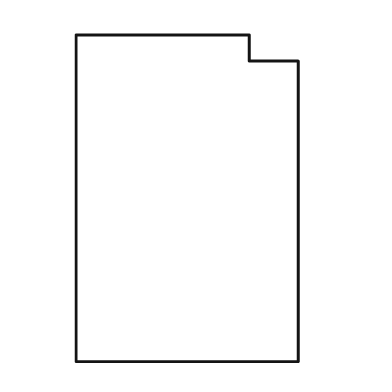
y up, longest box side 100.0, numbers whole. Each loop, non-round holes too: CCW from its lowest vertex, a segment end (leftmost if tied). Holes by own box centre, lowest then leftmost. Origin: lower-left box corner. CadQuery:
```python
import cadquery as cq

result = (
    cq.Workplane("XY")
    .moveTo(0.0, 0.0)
    .lineTo(68.0, 0.0)
    .lineTo(68.0, 92.0)
    .lineTo(53.0, 92.0)
    .lineTo(53.0, 100.0)
    .lineTo(0.0, 100.0)
    .close()
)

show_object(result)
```